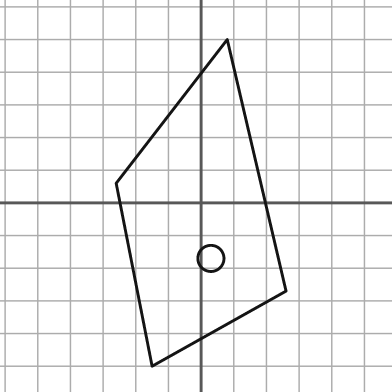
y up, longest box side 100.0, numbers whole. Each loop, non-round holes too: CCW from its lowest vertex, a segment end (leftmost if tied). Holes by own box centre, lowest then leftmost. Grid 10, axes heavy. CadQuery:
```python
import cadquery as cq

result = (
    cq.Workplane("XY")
    .moveTo(-15.0, -50.0)
    .lineTo(26.0, -27.0)
    .lineTo(8.0, 50.0)
    .lineTo(-26.0, 6.0)
    .close()
    .moveTo(3.0, -17.0)
    .circle(4.0)
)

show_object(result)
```